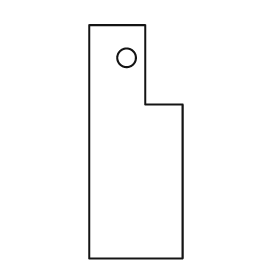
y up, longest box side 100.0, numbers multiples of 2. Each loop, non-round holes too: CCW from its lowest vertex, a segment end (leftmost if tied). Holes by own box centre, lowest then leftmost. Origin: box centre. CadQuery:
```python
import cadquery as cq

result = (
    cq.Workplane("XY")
    .moveTo(-20.0, -50.0)
    .lineTo(20.0, -50.0)
    .lineTo(20.0, 16.0)
    .lineTo(4.0, 16.0)
    .lineTo(4.0, 50.0)
    .lineTo(-20.0, 50.0)
    .close()
    .moveTo(-4.0, 36.0)
    .circle(4.0)
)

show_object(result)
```